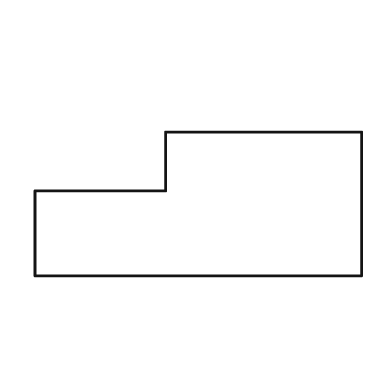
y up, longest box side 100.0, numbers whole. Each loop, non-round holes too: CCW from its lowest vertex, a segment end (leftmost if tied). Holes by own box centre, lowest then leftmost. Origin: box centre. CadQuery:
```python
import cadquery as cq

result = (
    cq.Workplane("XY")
    .moveTo(-50.0, -22.0)
    .lineTo(50.0, -22.0)
    .lineTo(50.0, 22.0)
    .lineTo(-10.0, 22.0)
    .lineTo(-10.0, 4.0)
    .lineTo(-50.0, 4.0)
    .close()
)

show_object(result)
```